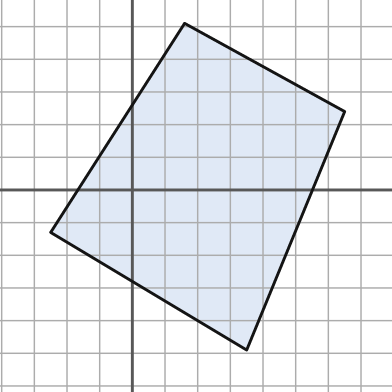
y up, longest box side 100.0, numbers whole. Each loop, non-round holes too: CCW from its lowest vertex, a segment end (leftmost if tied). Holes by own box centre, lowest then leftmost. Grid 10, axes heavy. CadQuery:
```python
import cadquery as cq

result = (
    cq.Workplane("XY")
    .moveTo(35.0, -49.0)
    .lineTo(65.0, 24.0)
    .lineTo(16.0, 51.0)
    .lineTo(-25.0, -13.0)
    .close()
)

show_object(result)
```